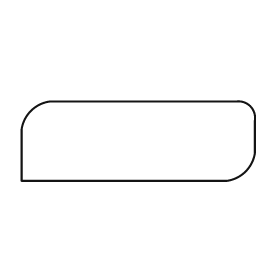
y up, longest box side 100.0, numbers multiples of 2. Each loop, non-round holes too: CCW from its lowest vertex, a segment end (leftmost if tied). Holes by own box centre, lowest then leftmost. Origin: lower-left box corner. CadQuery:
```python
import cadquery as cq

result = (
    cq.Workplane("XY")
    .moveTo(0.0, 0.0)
    .lineTo(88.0, 0.0)
    .threePointArc((96.0, 4.0), (100.0, 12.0))
    .lineTo(100.0, 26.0)
    .threePointArc((98.0, 32.0), (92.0, 34.0))
    .lineTo(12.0, 34.0)
    .threePointArc((4.0, 30.0), (0.0, 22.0))
    .close()
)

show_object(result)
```